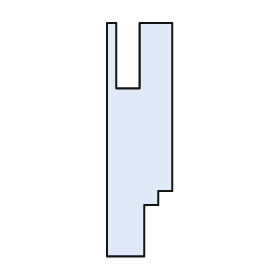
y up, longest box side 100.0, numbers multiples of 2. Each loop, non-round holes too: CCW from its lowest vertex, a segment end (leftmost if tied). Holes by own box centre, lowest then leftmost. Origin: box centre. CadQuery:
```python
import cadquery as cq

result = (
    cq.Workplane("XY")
    .moveTo(-14.0, -50.0)
    .lineTo(2.0, -50.0)
    .lineTo(2.0, -28.0)
    .lineTo(8.0, -28.0)
    .lineTo(8.0, -22.0)
    .lineTo(14.0, -22.0)
    .lineTo(14.0, 50.0)
    .lineTo(0.0, 50.0)
    .lineTo(0.0, 22.0)
    .lineTo(-10.0, 22.0)
    .lineTo(-10.0, 50.0)
    .lineTo(-14.0, 50.0)
    .close()
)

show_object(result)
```